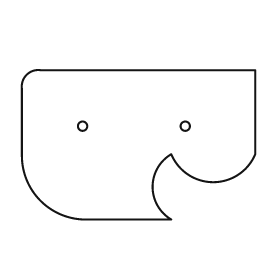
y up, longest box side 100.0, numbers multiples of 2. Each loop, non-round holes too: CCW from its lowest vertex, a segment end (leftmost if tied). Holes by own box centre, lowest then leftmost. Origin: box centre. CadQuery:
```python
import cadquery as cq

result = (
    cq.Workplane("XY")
    .moveTo(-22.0, -32.0)
    .lineTo(14.0, -32.0)
    .threePointArc((6.0, -18.0), (14.0, -4.0))
    .threePointArc((32.0, -16.0), (50.0, -4.0))
    .lineTo(50.0, 32.0)
    .lineTo(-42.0, 32.0)
    .threePointArc((-48.0, 30.0), (-50.0, 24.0))
    .lineTo(-50.0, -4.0)
    .threePointArc((-42.0, -24.0), (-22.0, -32.0))
    .close()
    .moveTo(-24.0, 8.0)
    .circle(2.0)
    .moveTo(20.0, 8.0)
    .circle(2.0)
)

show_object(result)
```